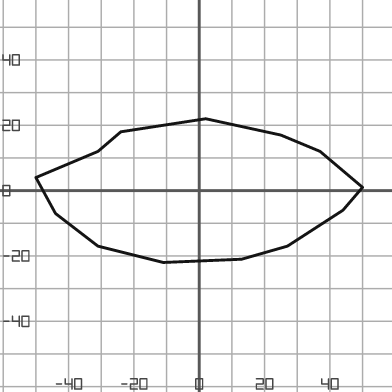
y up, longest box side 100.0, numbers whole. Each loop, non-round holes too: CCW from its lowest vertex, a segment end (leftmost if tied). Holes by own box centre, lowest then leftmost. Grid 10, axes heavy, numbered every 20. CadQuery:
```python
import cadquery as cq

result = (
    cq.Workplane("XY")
    .moveTo(-11.0, -22.0)
    .lineTo(13.0, -21.0)
    .lineTo(27.0, -17.0)
    .lineTo(44.0, -6.0)
    .lineTo(50.0, 1.0)
    .lineTo(37.0, 12.0)
    .lineTo(25.0, 17.0)
    .lineTo(2.0, 22.0)
    .lineTo(-24.0, 18.0)
    .lineTo(-31.0, 12.0)
    .lineTo(-50.0, 4.0)
    .lineTo(-44.0, -7.0)
    .lineTo(-31.0, -17.0)
    .close()
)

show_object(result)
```